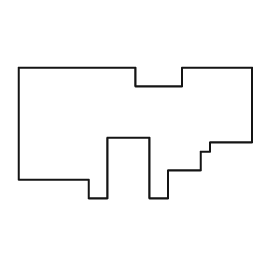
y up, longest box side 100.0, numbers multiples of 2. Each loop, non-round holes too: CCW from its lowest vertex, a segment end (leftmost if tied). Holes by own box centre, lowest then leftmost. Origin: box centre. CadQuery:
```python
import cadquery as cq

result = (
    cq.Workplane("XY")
    .moveTo(-20.0, -28.0)
    .lineTo(-12.0, -28.0)
    .lineTo(-12.0, -2.0)
    .lineTo(6.0, -2.0)
    .lineTo(6.0, -28.0)
    .lineTo(14.0, -28.0)
    .lineTo(14.0, -16.0)
    .lineTo(28.0, -16.0)
    .lineTo(28.0, -8.0)
    .lineTo(32.0, -8.0)
    .lineTo(32.0, -4.0)
    .lineTo(50.0, -4.0)
    .lineTo(50.0, 28.0)
    .lineTo(20.0, 28.0)
    .lineTo(20.0, 20.0)
    .lineTo(0.0, 20.0)
    .lineTo(0.0, 28.0)
    .lineTo(-50.0, 28.0)
    .lineTo(-50.0, -20.0)
    .lineTo(-20.0, -20.0)
    .close()
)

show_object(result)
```